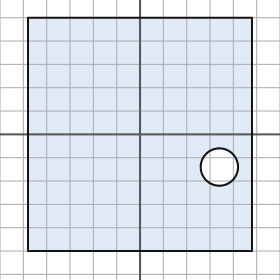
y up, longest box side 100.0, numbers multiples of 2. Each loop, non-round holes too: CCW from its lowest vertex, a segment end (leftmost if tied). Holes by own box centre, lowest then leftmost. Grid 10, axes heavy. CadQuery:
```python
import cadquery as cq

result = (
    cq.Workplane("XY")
    .moveTo(-48.0, -50.0)
    .lineTo(48.0, -50.0)
    .lineTo(48.0, 50.0)
    .lineTo(-48.0, 50.0)
    .close()
    .moveTo(34.0, -14.0)
    .circle(8.0)
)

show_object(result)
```